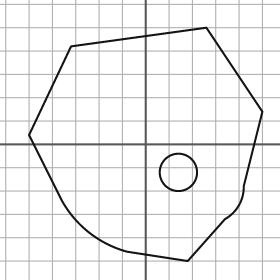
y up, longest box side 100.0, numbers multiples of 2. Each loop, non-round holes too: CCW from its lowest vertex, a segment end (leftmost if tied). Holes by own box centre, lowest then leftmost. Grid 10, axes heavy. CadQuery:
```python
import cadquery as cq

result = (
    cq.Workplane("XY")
    .moveTo(18.0, -50.0)
    .lineTo(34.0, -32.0)
    .threePointArc((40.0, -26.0), (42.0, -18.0))
    .lineTo(50.0, 14.0)
    .lineTo(26.0, 50.0)
    .lineTo(-32.0, 42.0)
    .lineTo(-50.0, 4.0)
    .lineTo(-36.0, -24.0)
    .threePointArc((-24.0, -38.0), (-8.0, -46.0))
    .close()
    .moveTo(14.0, -12.0)
    .circle(8.0)
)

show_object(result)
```